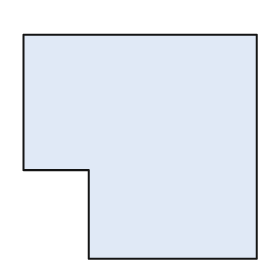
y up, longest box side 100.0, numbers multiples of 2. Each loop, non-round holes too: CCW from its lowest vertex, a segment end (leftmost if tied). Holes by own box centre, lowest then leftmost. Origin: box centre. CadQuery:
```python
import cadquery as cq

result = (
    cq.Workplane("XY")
    .moveTo(-22.0, -48.0)
    .lineTo(50.0, -48.0)
    .lineTo(50.0, 48.0)
    .lineTo(-50.0, 48.0)
    .lineTo(-50.0, -10.0)
    .lineTo(-22.0, -10.0)
    .close()
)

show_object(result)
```